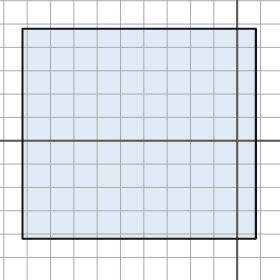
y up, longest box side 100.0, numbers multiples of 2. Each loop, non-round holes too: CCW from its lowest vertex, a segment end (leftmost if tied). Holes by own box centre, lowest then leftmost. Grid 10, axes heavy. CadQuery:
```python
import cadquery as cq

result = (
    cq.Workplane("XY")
    .moveTo(-92.0, -42.0)
    .lineTo(8.0, -42.0)
    .lineTo(8.0, 48.0)
    .lineTo(-92.0, 48.0)
    .close()
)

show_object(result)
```